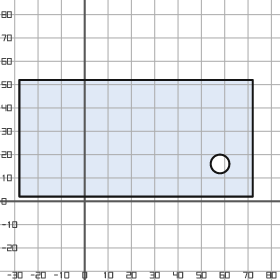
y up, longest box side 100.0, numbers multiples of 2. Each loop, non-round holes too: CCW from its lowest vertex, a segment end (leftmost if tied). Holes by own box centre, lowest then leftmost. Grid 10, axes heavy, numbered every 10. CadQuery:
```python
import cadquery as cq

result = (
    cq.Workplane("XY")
    .moveTo(-28.0, 2.0)
    .lineTo(72.0, 2.0)
    .lineTo(72.0, 52.0)
    .lineTo(-28.0, 52.0)
    .close()
    .moveTo(58.0, 16.0)
    .circle(4.0)
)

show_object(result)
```